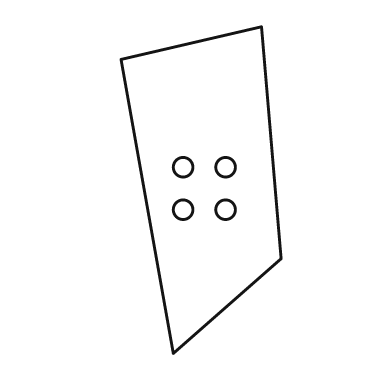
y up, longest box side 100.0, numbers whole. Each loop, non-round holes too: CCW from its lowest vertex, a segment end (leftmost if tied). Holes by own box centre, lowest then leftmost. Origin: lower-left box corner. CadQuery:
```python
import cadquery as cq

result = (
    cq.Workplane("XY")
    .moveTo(16.0, 0.0)
    .lineTo(49.0, 29.0)
    .lineTo(43.0, 100.0)
    .lineTo(0.0, 90.0)
    .close()
    .moveTo(19.0, 44.0)
    .circle(3.0)
    .moveTo(32.0, 44.0)
    .circle(3.0)
    .moveTo(19.0, 57.0)
    .circle(3.0)
    .moveTo(32.0, 57.0)
    .circle(3.0)
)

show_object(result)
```